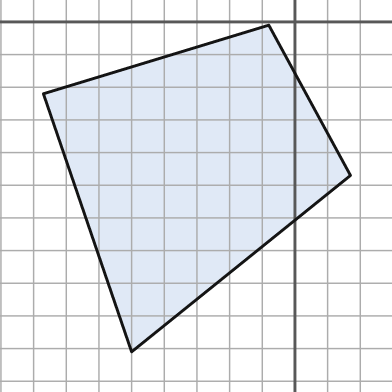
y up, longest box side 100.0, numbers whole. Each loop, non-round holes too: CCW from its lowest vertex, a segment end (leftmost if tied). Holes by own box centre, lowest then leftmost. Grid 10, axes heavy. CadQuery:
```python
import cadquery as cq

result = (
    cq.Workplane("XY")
    .moveTo(-50.0, -101.0)
    .lineTo(17.0, -47.0)
    .lineTo(-8.0, -1.0)
    .lineTo(-77.0, -22.0)
    .close()
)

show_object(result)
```